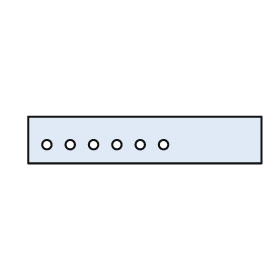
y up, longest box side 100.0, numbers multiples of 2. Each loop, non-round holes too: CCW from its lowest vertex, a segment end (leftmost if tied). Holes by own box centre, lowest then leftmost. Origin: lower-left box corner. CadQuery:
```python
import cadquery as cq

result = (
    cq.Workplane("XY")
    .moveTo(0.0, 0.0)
    .lineTo(100.0, 0.0)
    .lineTo(100.0, 20.0)
    .lineTo(0.0, 20.0)
    .close()
    .moveTo(8.0, 8.0)
    .circle(2.0)
    .moveTo(18.0, 8.0)
    .circle(2.0)
    .moveTo(28.0, 8.0)
    .circle(2.0)
    .moveTo(38.0, 8.0)
    .circle(2.0)
    .moveTo(48.0, 8.0)
    .circle(2.0)
    .moveTo(58.0, 8.0)
    .circle(2.0)
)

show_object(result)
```